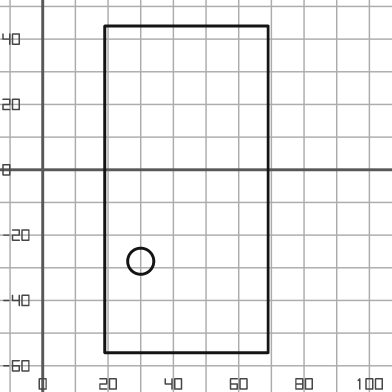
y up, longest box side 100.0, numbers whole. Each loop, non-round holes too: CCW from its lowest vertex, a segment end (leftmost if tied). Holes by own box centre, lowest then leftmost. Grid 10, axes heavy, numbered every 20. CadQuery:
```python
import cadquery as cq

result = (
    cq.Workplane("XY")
    .moveTo(19.0, -56.0)
    .lineTo(69.0, -56.0)
    .lineTo(69.0, 44.0)
    .lineTo(19.0, 44.0)
    .close()
    .moveTo(30.0, -28.0)
    .circle(4.0)
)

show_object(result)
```